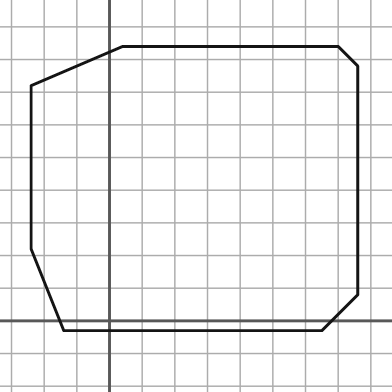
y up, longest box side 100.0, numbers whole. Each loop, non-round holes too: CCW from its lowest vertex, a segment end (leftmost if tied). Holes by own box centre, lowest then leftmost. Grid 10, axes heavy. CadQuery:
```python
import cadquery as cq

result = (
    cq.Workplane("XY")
    .moveTo(-14.0, -3.0)
    .lineTo(65.0, -3.0)
    .lineTo(76.0, 8.0)
    .lineTo(76.0, 78.0)
    .lineTo(70.0, 84.0)
    .lineTo(4.0, 84.0)
    .lineTo(-24.0, 72.0)
    .lineTo(-24.0, 22.0)
    .close()
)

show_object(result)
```